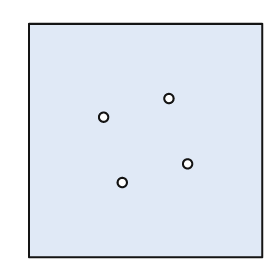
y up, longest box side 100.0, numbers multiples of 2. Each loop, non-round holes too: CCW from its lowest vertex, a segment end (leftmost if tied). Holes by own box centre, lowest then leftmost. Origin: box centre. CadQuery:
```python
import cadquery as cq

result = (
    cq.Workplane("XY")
    .moveTo(-50.0, -50.0)
    .lineTo(50.0, -50.0)
    .lineTo(50.0, 50.0)
    .lineTo(-50.0, 50.0)
    .close()
    .moveTo(-10.0, -18.0)
    .circle(2.0)
    .moveTo(18.0, -10.0)
    .circle(2.0)
    .moveTo(-18.0, 10.0)
    .circle(2.0)
    .moveTo(10.0, 18.0)
    .circle(2.0)
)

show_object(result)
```